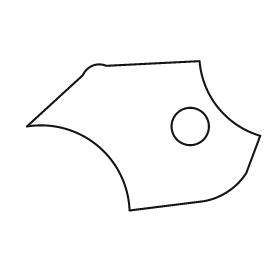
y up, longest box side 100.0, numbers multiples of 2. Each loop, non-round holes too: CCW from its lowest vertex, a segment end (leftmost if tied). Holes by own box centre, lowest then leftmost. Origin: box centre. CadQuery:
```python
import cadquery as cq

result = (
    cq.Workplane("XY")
    .moveTo(-6.0, -32.0)
    .lineTo(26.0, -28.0)
    .threePointArc((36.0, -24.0), (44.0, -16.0))
    .lineTo(50.0, 0.0)
    .threePointArc((32.0, 12.0), (24.0, 32.0))
    .lineTo(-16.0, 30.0)
    .threePointArc((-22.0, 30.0), (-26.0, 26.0))
    .lineTo(-50.0, 4.0)
    .threePointArc((-20.0, -4.0), (-6.0, -32.0))
    .close()
    .moveTo(20.0, 4.0)
    .circle(8.0)
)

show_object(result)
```